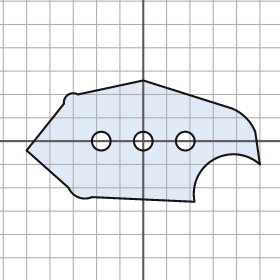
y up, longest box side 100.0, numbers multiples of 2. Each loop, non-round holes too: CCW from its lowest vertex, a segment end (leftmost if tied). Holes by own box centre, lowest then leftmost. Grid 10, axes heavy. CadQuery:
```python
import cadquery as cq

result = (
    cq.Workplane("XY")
    .moveTo(22.0, -26.0)
    .threePointArc((30.0, -8.0), (50.0, -10.0))
    .lineTo(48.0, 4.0)
    .threePointArc((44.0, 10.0), (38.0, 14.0))
    .lineTo(0.0, 26.0)
    .lineTo(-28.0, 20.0)
    .threePointArc((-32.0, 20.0), (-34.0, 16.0))
    .lineTo(-50.0, -4.0)
    .lineTo(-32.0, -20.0)
    .threePointArc((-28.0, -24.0), (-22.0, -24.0))
    .close()
    .moveTo(-18.0, 0.0)
    .circle(4.0)
    .moveTo(0.0, 0.0)
    .circle(4.0)
    .moveTo(18.0, 0.0)
    .circle(4.0)
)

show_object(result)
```